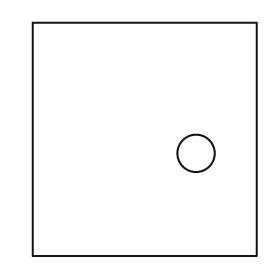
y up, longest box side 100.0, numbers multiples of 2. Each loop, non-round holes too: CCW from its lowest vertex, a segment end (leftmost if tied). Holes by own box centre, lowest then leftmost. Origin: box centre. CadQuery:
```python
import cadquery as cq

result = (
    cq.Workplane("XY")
    .moveTo(-48.0, -50.0)
    .lineTo(48.0, -50.0)
    .lineTo(48.0, 50.0)
    .lineTo(-48.0, 50.0)
    .close()
    .moveTo(22.0, -6.0)
    .circle(8.0)
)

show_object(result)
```